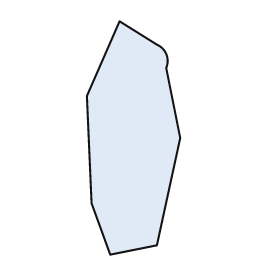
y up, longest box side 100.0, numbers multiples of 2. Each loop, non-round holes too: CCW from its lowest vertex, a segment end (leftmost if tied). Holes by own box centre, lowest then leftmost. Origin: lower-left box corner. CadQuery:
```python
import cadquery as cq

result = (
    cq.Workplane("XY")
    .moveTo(10.0, 0.0)
    .lineTo(30.0, 4.0)
    .lineTo(40.0, 50.0)
    .lineTo(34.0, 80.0)
    .threePointArc((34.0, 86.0), (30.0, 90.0))
    .lineTo(14.0, 100.0)
    .lineTo(0.0, 68.0)
    .lineTo(2.0, 22.0)
    .close()
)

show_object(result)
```